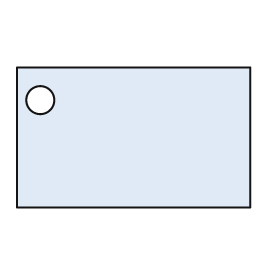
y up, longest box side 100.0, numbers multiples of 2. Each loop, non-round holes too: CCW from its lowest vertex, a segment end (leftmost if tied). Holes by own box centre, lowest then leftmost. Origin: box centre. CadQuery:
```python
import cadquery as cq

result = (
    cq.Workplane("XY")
    .moveTo(-50.0, -30.0)
    .lineTo(50.0, -30.0)
    .lineTo(50.0, 30.0)
    .lineTo(-50.0, 30.0)
    .close()
    .moveTo(-40.0, 16.0)
    .circle(6.0)
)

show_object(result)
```